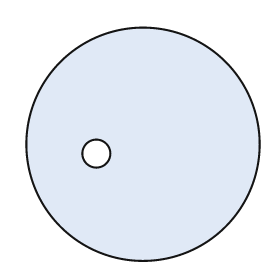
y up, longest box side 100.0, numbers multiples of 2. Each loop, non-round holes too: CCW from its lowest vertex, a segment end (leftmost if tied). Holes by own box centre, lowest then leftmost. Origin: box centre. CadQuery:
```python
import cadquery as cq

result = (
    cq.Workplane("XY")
    .moveTo(0.0, 0.0)
    .circle(50.0)
    .moveTo(-20.0, -4.0)
    .circle(6.0)
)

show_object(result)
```